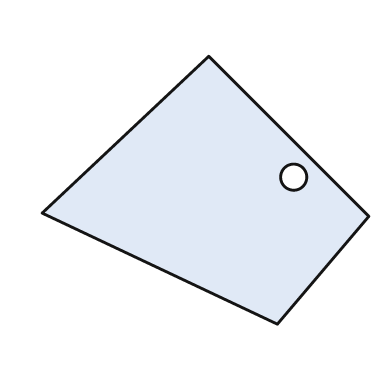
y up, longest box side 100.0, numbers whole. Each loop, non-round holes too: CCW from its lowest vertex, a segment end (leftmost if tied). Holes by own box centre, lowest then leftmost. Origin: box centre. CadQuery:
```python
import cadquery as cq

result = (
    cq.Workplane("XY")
    .moveTo(22.0, -41.0)
    .lineTo(50.0, -8.0)
    .lineTo(1.0, 41.0)
    .lineTo(-50.0, -7.0)
    .close()
    .moveTo(27.0, 4.0)
    .circle(4.0)
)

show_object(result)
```